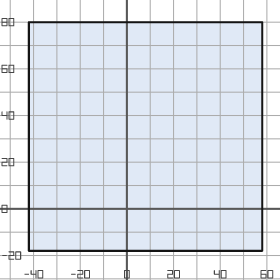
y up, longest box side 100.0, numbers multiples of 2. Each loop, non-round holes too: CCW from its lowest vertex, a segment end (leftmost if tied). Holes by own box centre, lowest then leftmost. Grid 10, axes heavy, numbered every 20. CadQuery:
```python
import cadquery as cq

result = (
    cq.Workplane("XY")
    .moveTo(-42.0, -18.0)
    .lineTo(58.0, -18.0)
    .lineTo(58.0, 80.0)
    .lineTo(-42.0, 80.0)
    .close()
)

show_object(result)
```